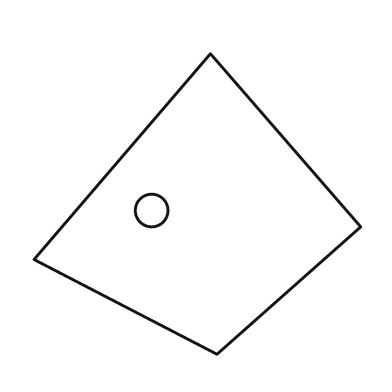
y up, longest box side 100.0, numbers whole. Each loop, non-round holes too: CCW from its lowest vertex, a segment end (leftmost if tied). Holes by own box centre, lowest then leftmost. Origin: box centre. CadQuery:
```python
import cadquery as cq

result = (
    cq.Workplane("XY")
    .moveTo(6.0, -46.0)
    .lineTo(50.0, -7.0)
    .lineTo(4.0, 46.0)
    .lineTo(-50.0, -17.0)
    .close()
    .moveTo(-14.0, -2.0)
    .circle(5.0)
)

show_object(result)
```